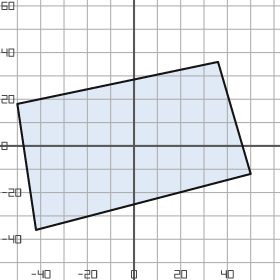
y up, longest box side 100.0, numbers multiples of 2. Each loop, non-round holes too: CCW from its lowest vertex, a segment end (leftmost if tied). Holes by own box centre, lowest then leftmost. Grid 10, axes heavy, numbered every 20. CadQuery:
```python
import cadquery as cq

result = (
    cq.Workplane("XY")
    .moveTo(-42.0, -36.0)
    .lineTo(50.0, -12.0)
    .lineTo(36.0, 36.0)
    .lineTo(-50.0, 18.0)
    .close()
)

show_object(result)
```